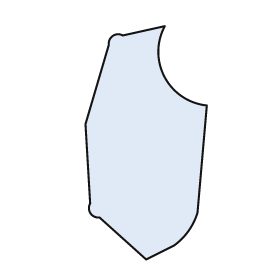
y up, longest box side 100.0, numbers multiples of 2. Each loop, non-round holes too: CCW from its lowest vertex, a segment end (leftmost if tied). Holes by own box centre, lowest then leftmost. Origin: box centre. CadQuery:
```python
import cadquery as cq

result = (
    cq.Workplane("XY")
    .moveTo(0.0, -50.0)
    .lineTo(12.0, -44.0)
    .threePointArc((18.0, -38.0), (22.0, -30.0))
    .lineTo(26.0, 16.0)
    .threePointArc((8.0, 28.0), (8.0, 50.0))
    .lineTo(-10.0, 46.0)
    .threePointArc((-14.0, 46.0), (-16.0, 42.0))
    .lineTo(-26.0, 8.0)
    .lineTo(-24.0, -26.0)
    .threePointArc((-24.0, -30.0), (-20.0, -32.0))
    .close()
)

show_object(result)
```